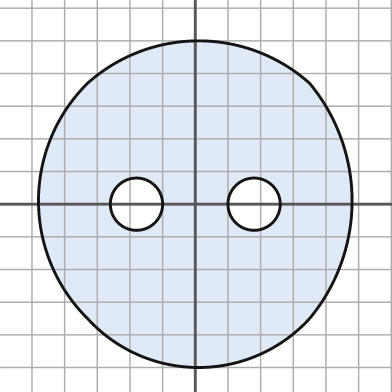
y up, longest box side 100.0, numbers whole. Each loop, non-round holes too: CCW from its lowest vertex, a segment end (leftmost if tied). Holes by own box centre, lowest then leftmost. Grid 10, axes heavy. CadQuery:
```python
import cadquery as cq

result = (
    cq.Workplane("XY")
    .moveTo(-33.0, -35.0)
    .threePointArc((1.0, -50.0), (35.0, -35.0))
    .threePointArc((48.0, 1.0), (35.0, 37.0))
    .threePointArc((1.0, 50.0), (-33.0, 37.0))
    .threePointArc((-48.0, 1.0), (-33.0, -35.0))
    .close()
    .moveTo(-18.0, 0.0)
    .circle(8.0)
    .moveTo(18.0, 0.0)
    .circle(8.0)
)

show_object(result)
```